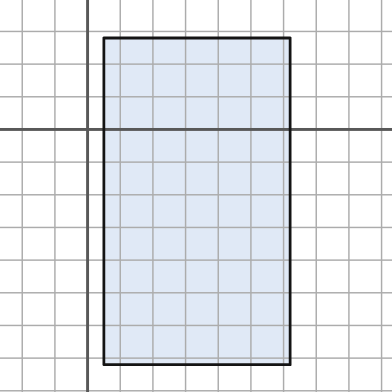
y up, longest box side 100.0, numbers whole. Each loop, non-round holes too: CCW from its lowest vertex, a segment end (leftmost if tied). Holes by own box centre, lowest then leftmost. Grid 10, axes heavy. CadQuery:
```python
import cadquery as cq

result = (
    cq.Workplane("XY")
    .moveTo(5.0, -72.0)
    .lineTo(62.0, -72.0)
    .lineTo(62.0, 28.0)
    .lineTo(5.0, 28.0)
    .close()
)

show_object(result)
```